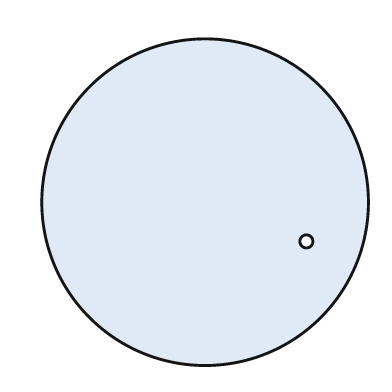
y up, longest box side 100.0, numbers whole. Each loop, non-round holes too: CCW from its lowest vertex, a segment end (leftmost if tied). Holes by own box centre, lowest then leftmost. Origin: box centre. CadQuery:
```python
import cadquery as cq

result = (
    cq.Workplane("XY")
    .moveTo(0.0, 0.0)
    .circle(50.0)
    .moveTo(31.0, -12.0)
    .circle(2.0)
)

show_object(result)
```